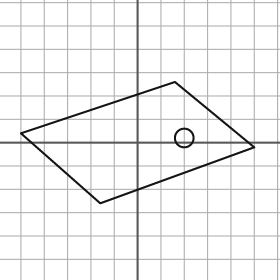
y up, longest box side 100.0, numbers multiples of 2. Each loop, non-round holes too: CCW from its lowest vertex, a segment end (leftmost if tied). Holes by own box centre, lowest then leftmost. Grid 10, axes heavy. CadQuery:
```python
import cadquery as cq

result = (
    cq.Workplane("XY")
    .moveTo(-16.0, -26.0)
    .lineTo(50.0, -2.0)
    .lineTo(16.0, 26.0)
    .lineTo(-50.0, 4.0)
    .close()
    .moveTo(20.0, 2.0)
    .circle(4.0)
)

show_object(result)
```